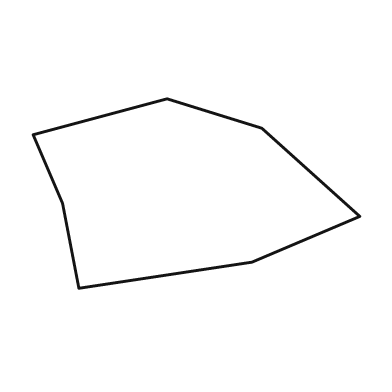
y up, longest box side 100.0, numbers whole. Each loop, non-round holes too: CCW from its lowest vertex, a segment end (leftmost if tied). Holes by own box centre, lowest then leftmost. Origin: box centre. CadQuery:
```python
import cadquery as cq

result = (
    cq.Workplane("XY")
    .moveTo(-36.0, -29.0)
    .lineTo(17.0, -21.0)
    .lineTo(50.0, -7.0)
    .lineTo(20.0, 20.0)
    .lineTo(-9.0, 29.0)
    .lineTo(-50.0, 18.0)
    .lineTo(-41.0, -3.0)
    .close()
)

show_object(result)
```